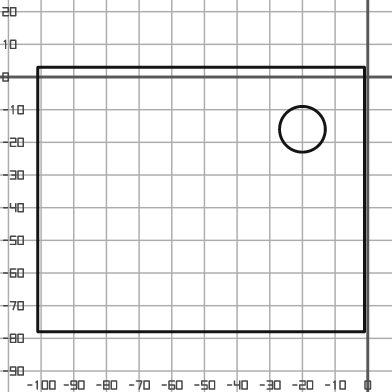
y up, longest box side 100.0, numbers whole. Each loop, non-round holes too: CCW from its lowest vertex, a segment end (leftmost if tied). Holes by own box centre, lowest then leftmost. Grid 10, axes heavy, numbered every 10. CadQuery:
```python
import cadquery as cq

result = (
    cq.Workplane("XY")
    .moveTo(-101.0, -78.0)
    .lineTo(-1.0, -78.0)
    .lineTo(-1.0, 3.0)
    .lineTo(-101.0, 3.0)
    .close()
    .moveTo(-20.0, -16.0)
    .circle(7.0)
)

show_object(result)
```